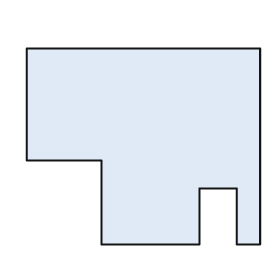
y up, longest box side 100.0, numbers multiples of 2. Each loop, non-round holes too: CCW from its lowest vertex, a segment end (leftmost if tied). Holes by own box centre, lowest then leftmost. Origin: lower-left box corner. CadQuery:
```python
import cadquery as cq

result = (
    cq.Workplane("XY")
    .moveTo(32.0, 0.0)
    .lineTo(74.0, 0.0)
    .lineTo(74.0, 24.0)
    .lineTo(90.0, 24.0)
    .lineTo(90.0, 0.0)
    .lineTo(100.0, 0.0)
    .lineTo(100.0, 84.0)
    .lineTo(0.0, 84.0)
    .lineTo(0.0, 36.0)
    .lineTo(32.0, 36.0)
    .close()
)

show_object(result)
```